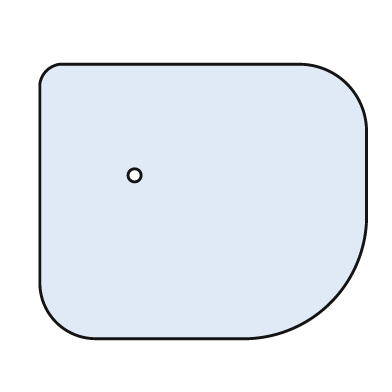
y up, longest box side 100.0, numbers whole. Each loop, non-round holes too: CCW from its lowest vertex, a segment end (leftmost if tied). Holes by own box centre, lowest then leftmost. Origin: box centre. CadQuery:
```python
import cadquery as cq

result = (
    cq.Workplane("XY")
    .moveTo(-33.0, -42.0)
    .lineTo(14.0, -42.0)
    .threePointArc((39.0, -31.0), (50.0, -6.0))
    .lineTo(50.0, 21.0)
    .threePointArc((44.0, 36.0), (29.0, 42.0))
    .lineTo(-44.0, 42.0)
    .threePointArc((-48.0, 40.0), (-50.0, 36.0))
    .lineTo(-50.0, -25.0)
    .threePointArc((-45.0, -37.0), (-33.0, -42.0))
    .close()
    .moveTo(-21.0, 8.0)
    .circle(2.0)
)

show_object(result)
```